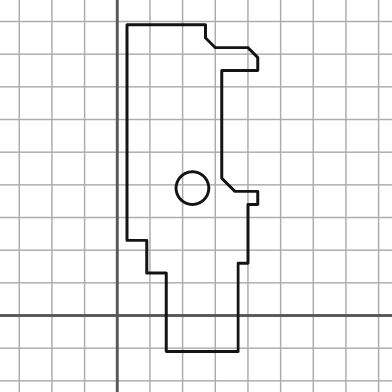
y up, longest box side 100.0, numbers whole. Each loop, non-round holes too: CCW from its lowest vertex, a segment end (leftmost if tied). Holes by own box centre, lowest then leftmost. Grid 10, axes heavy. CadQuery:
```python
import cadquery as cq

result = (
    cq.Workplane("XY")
    .moveTo(15.0, -11.0)
    .lineTo(37.0, -11.0)
    .lineTo(37.0, 16.0)
    .lineTo(40.0, 16.0)
    .lineTo(40.0, 34.0)
    .lineTo(43.0, 34.0)
    .lineTo(43.0, 38.0)
    .lineTo(36.0, 38.0)
    .lineTo(32.0, 42.0)
    .lineTo(32.0, 75.0)
    .lineTo(43.0, 75.0)
    .lineTo(43.0, 79.0)
    .lineTo(40.0, 82.0)
    .lineTo(30.0, 82.0)
    .lineTo(27.0, 85.0)
    .lineTo(27.0, 89.0)
    .lineTo(3.0, 89.0)
    .lineTo(3.0, 23.0)
    .lineTo(9.0, 23.0)
    .lineTo(9.0, 13.0)
    .lineTo(15.0, 13.0)
    .close()
    .moveTo(23.0, 39.0)
    .circle(5.0)
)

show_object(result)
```